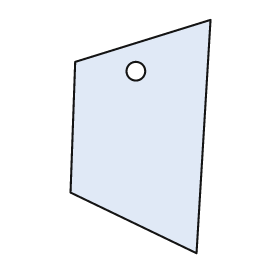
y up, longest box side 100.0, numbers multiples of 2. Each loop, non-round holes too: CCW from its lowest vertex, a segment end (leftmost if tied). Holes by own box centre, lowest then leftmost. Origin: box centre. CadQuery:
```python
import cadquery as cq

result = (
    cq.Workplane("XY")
    .moveTo(24.0, -50.0)
    .lineTo(30.0, 50.0)
    .lineTo(-28.0, 32.0)
    .lineTo(-30.0, -24.0)
    .close()
    .moveTo(-2.0, 28.0)
    .circle(4.0)
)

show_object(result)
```